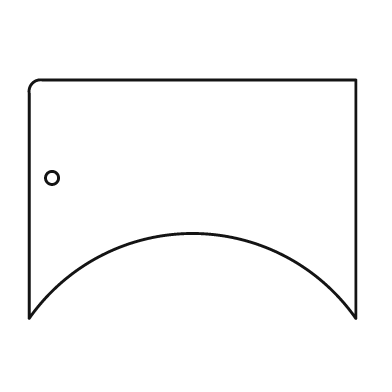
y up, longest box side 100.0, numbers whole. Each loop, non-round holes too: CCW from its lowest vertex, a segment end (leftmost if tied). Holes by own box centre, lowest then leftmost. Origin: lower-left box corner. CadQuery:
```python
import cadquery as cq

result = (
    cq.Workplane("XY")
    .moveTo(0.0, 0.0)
    .threePointArc((50.0, 26.0), (100.0, 0.0))
    .lineTo(100.0, 73.0)
    .lineTo(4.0, 73.0)
    .threePointArc((1.0, 72.0), (0.0, 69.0))
    .close()
    .moveTo(7.0, 43.0)
    .circle(2.0)
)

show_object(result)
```